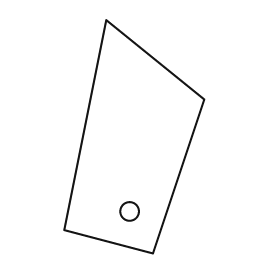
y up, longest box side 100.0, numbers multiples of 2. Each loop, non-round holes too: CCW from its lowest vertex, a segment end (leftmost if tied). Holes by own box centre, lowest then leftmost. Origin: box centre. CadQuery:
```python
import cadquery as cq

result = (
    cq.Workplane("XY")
    .moveTo(8.0, -50.0)
    .lineTo(30.0, 16.0)
    .lineTo(-12.0, 50.0)
    .lineTo(-30.0, -40.0)
    .close()
    .moveTo(-2.0, -32.0)
    .circle(4.0)
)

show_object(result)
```